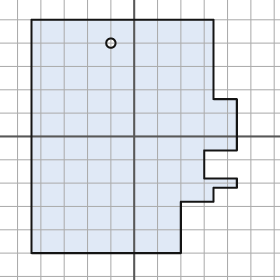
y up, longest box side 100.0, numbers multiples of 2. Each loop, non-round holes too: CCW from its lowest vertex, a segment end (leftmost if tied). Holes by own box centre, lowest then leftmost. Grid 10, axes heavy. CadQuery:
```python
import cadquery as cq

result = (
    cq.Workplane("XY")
    .moveTo(-44.0, -50.0)
    .lineTo(20.0, -50.0)
    .lineTo(20.0, -28.0)
    .lineTo(34.0, -28.0)
    .lineTo(34.0, -22.0)
    .lineTo(44.0, -22.0)
    .lineTo(44.0, -18.0)
    .lineTo(30.0, -18.0)
    .lineTo(30.0, -6.0)
    .lineTo(44.0, -6.0)
    .lineTo(44.0, 16.0)
    .lineTo(34.0, 16.0)
    .lineTo(34.0, 50.0)
    .lineTo(-44.0, 50.0)
    .close()
    .moveTo(-10.0, 40.0)
    .circle(2.0)
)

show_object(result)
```